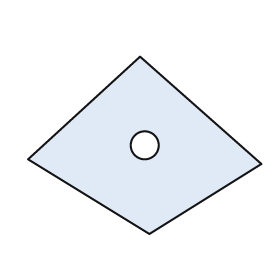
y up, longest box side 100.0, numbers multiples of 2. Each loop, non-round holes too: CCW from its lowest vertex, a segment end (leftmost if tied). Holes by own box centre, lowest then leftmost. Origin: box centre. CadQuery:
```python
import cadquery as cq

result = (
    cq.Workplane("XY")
    .moveTo(2.0, -38.0)
    .lineTo(50.0, -8.0)
    .lineTo(-2.0, 38.0)
    .lineTo(-50.0, -6.0)
    .close()
    .moveTo(0.0, 0.0)
    .circle(6.0)
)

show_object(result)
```